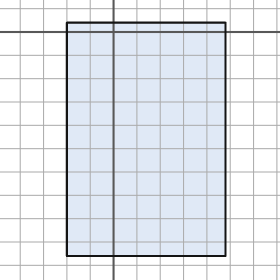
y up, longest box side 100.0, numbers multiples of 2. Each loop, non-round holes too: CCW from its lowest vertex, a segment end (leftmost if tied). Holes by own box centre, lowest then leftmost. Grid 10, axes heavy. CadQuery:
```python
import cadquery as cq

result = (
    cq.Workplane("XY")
    .moveTo(-20.0, -96.0)
    .lineTo(48.0, -96.0)
    .lineTo(48.0, 4.0)
    .lineTo(-20.0, 4.0)
    .close()
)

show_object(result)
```